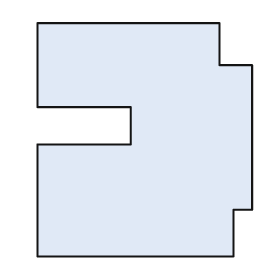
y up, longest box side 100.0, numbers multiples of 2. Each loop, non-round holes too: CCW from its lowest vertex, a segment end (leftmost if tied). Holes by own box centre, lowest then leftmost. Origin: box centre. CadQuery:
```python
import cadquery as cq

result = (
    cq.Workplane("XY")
    .moveTo(-46.0, -50.0)
    .lineTo(38.0, -50.0)
    .lineTo(38.0, -30.0)
    .lineTo(46.0, -30.0)
    .lineTo(46.0, 32.0)
    .lineTo(32.0, 32.0)
    .lineTo(32.0, 50.0)
    .lineTo(-46.0, 50.0)
    .lineTo(-46.0, 14.0)
    .lineTo(-6.0, 14.0)
    .lineTo(-6.0, -2.0)
    .lineTo(-46.0, -2.0)
    .close()
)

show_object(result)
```